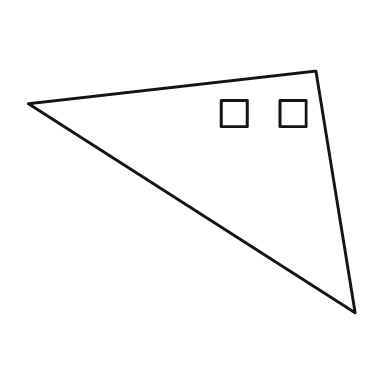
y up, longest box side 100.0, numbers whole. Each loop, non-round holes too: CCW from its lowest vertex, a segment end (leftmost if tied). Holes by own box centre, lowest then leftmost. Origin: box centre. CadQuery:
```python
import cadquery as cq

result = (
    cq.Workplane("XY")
    .moveTo(50.0, -37.0)
    .lineTo(38.0, 37.0)
    .lineTo(-50.0, 27.0)
    .close()
    .moveTo(9.0, 20.0)
    .lineTo(17.0, 20.0)
    .lineTo(17.0, 28.0)
    .lineTo(9.0, 28.0)
    .close()
    .moveTo(27.0, 20.0)
    .lineTo(35.0, 20.0)
    .lineTo(35.0, 28.0)
    .lineTo(27.0, 28.0)
    .close()
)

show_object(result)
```